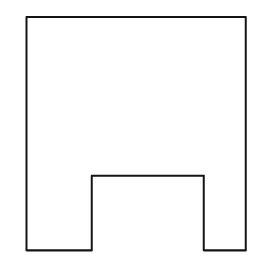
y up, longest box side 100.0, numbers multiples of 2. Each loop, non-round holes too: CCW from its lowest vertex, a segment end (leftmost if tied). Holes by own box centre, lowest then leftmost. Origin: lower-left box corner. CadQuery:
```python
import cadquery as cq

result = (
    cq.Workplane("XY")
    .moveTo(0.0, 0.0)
    .lineTo(28.0, 0.0)
    .lineTo(28.0, 32.0)
    .lineTo(76.0, 32.0)
    .lineTo(76.0, 0.0)
    .lineTo(94.0, 0.0)
    .lineTo(94.0, 100.0)
    .lineTo(0.0, 100.0)
    .close()
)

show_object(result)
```